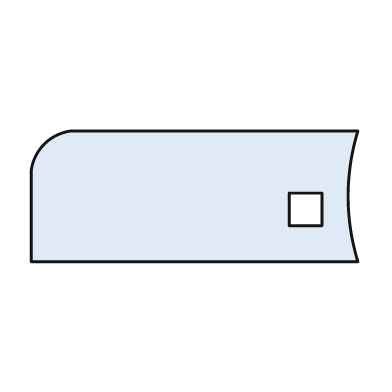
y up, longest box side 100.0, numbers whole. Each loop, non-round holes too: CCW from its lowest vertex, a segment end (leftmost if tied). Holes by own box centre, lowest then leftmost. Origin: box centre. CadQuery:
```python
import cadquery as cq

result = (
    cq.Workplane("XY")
    .moveTo(-50.0, -20.0)
    .lineTo(50.0, -20.0)
    .threePointArc((47.0, 0.0), (50.0, 20.0))
    .lineTo(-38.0, 20.0)
    .threePointArc((-46.0, 16.0), (-50.0, 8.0))
    .close()
    .moveTo(29.0, -9.0)
    .lineTo(39.0, -9.0)
    .lineTo(39.0, 1.0)
    .lineTo(29.0, 1.0)
    .close()
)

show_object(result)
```